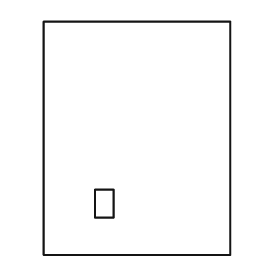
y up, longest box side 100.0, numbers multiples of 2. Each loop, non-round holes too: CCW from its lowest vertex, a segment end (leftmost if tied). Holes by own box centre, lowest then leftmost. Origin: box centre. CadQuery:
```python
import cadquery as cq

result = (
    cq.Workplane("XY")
    .moveTo(-40.0, -50.0)
    .lineTo(40.0, -50.0)
    .lineTo(40.0, 50.0)
    .lineTo(-40.0, 50.0)
    .close()
    .moveTo(-18.0, -34.0)
    .lineTo(-10.0, -34.0)
    .lineTo(-10.0, -22.0)
    .lineTo(-18.0, -22.0)
    .close()
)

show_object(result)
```